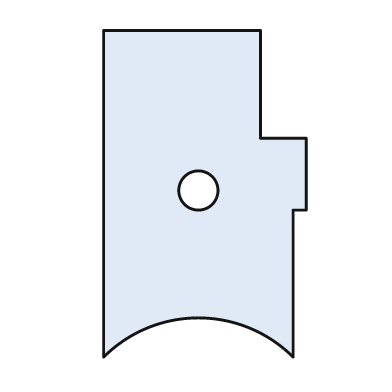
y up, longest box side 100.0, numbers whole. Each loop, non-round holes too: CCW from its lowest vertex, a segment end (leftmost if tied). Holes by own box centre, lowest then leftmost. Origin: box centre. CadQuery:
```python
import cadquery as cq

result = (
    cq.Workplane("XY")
    .moveTo(-31.0, -50.0)
    .threePointArc((-2.0, -38.0), (27.0, -50.0))
    .lineTo(27.0, -5.0)
    .lineTo(31.0, -5.0)
    .lineTo(31.0, 17.0)
    .lineTo(17.0, 17.0)
    .lineTo(17.0, 50.0)
    .lineTo(-31.0, 50.0)
    .close()
    .moveTo(-2.0, 1.0)
    .circle(6.0)
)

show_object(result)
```